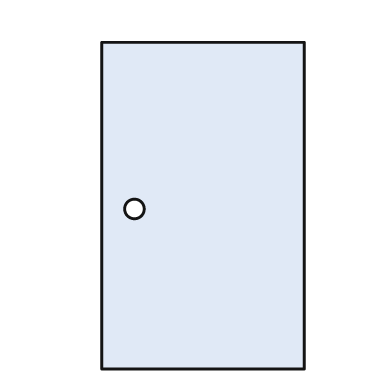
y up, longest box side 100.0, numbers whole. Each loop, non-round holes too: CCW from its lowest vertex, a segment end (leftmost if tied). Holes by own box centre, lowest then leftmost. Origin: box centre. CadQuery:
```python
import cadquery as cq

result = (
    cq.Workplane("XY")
    .moveTo(-31.0, -50.0)
    .lineTo(31.0, -50.0)
    .lineTo(31.0, 50.0)
    .lineTo(-31.0, 50.0)
    .close()
    .moveTo(-21.0, -1.0)
    .circle(3.0)
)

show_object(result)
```